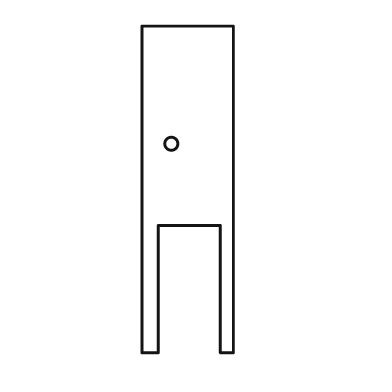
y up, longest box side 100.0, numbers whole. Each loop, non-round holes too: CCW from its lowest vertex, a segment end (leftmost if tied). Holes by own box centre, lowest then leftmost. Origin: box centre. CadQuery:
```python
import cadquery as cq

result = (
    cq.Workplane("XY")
    .moveTo(-14.0, -50.0)
    .lineTo(-9.0, -50.0)
    .lineTo(-9.0, -11.0)
    .lineTo(10.0, -11.0)
    .lineTo(10.0, -50.0)
    .lineTo(14.0, -50.0)
    .lineTo(14.0, 50.0)
    .lineTo(-14.0, 50.0)
    .close()
    .moveTo(-5.0, 14.0)
    .circle(2.0)
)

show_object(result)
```